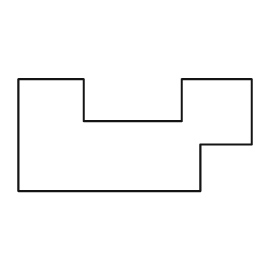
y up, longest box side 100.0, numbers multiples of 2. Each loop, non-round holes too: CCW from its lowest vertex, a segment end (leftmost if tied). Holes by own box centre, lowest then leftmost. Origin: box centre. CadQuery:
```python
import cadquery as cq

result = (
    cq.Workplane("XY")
    .moveTo(-50.0, -24.0)
    .lineTo(28.0, -24.0)
    .lineTo(28.0, -4.0)
    .lineTo(50.0, -4.0)
    .lineTo(50.0, 24.0)
    .lineTo(20.0, 24.0)
    .lineTo(20.0, 6.0)
    .lineTo(-22.0, 6.0)
    .lineTo(-22.0, 24.0)
    .lineTo(-50.0, 24.0)
    .close()
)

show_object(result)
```